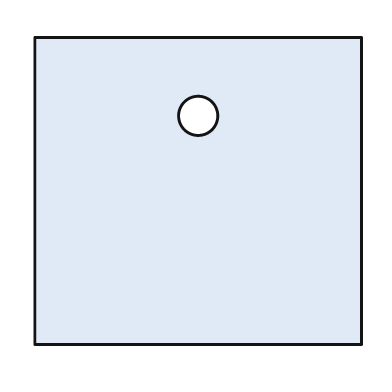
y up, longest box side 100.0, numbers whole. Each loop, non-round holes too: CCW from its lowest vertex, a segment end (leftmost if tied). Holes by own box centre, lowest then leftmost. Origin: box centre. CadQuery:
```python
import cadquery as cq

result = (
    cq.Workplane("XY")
    .moveTo(-50.0, -47.0)
    .lineTo(50.0, -47.0)
    .lineTo(50.0, 47.0)
    .lineTo(-50.0, 47.0)
    .close()
    .moveTo(0.0, 23.0)
    .circle(6.0)
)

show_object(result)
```